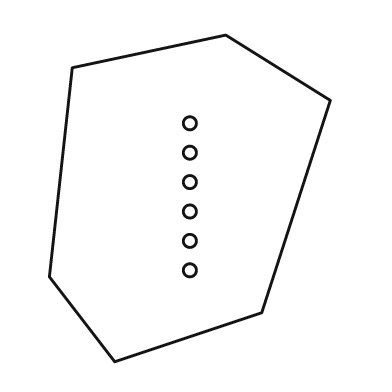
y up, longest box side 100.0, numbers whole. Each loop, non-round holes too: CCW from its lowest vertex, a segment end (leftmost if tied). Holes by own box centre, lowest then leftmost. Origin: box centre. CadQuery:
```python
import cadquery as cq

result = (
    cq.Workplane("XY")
    .moveTo(-23.0, -50.0)
    .lineTo(22.0, -35.0)
    .lineTo(43.0, 30.0)
    .lineTo(11.0, 50.0)
    .lineTo(-36.0, 40.0)
    .lineTo(-43.0, -24.0)
    .close()
    .moveTo(0.0, -22.0)
    .circle(2.0)
    .moveTo(0.0, -13.0)
    .circle(2.0)
    .moveTo(0.0, -4.0)
    .circle(2.0)
    .moveTo(0.0, 5.0)
    .circle(2.0)
    .moveTo(0.0, 14.0)
    .circle(2.0)
    .moveTo(0.0, 23.0)
    .circle(2.0)
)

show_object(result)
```